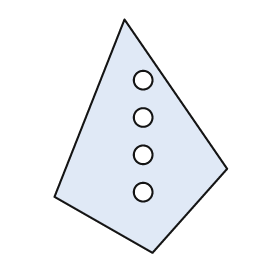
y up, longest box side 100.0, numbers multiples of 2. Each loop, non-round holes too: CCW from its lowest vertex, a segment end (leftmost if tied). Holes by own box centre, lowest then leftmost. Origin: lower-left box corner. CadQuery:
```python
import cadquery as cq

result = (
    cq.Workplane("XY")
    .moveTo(42.0, 0.0)
    .lineTo(74.0, 36.0)
    .lineTo(30.0, 100.0)
    .lineTo(0.0, 24.0)
    .close()
    .moveTo(38.0, 26.0)
    .circle(4.0)
    .moveTo(38.0, 42.0)
    .circle(4.0)
    .moveTo(38.0, 58.0)
    .circle(4.0)
    .moveTo(38.0, 74.0)
    .circle(4.0)
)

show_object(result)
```